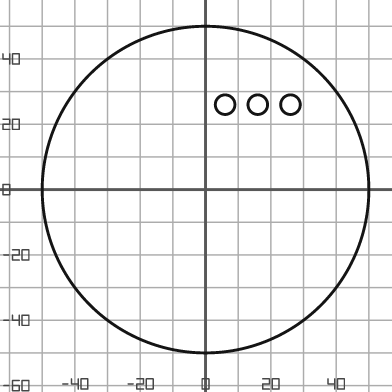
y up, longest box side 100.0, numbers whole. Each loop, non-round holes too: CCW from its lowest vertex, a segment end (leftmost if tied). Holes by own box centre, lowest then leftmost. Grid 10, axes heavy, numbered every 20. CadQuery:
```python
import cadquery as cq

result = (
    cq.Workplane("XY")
    .moveTo(0.0, 0.0)
    .circle(50.0)
    .moveTo(6.0, 26.0)
    .circle(3.0)
    .moveTo(16.0, 26.0)
    .circle(3.0)
    .moveTo(26.0, 26.0)
    .circle(3.0)
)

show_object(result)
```